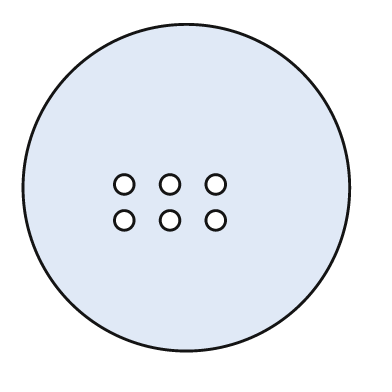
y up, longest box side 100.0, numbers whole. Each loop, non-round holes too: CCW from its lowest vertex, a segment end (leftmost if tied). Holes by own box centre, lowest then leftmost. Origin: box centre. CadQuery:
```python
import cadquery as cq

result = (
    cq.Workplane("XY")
    .moveTo(0.0, 0.0)
    .circle(50.0)
    .moveTo(-19.0, -10.0)
    .circle(3.0)
    .moveTo(-5.0, -10.0)
    .circle(3.0)
    .moveTo(9.0, -10.0)
    .circle(3.0)
    .moveTo(-19.0, 1.0)
    .circle(3.0)
    .moveTo(-5.0, 1.0)
    .circle(3.0)
    .moveTo(9.0, 1.0)
    .circle(3.0)
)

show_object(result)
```